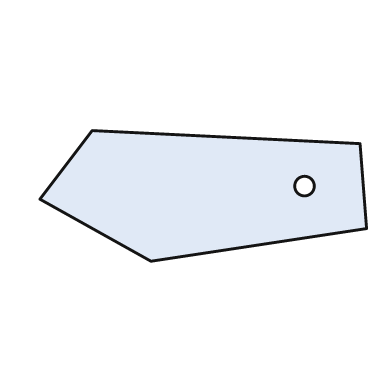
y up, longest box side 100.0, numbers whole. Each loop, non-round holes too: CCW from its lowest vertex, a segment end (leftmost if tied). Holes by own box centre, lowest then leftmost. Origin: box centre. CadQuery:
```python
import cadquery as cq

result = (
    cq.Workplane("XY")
    .moveTo(-16.0, -20.0)
    .lineTo(50.0, -10.0)
    .lineTo(48.0, 16.0)
    .lineTo(-34.0, 20.0)
    .lineTo(-50.0, -1.0)
    .close()
    .moveTo(31.0, 3.0)
    .circle(3.0)
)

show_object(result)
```